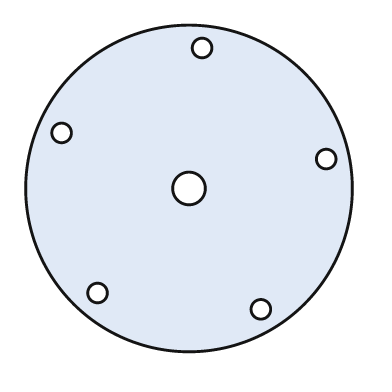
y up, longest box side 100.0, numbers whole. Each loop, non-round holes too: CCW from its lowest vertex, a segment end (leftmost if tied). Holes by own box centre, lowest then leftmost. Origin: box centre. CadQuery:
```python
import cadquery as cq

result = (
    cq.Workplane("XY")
    .moveTo(0.0, 0.0)
    .circle(50.0)
    .moveTo(22.0, -37.0)
    .circle(3.0)
    .moveTo(-28.0, -32.0)
    .circle(3.0)
    .moveTo(0.0, 0.0)
    .circle(5.0)
    .moveTo(42.0, 9.0)
    .circle(3.0)
    .moveTo(-39.0, 17.0)
    .circle(3.0)
    .moveTo(4.0, 43.0)
    .circle(3.0)
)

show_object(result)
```